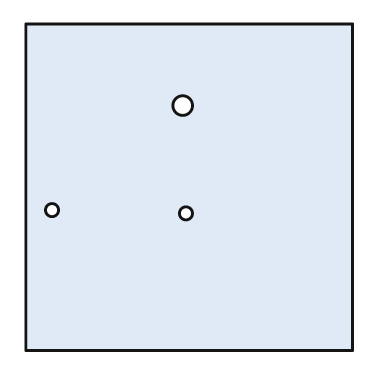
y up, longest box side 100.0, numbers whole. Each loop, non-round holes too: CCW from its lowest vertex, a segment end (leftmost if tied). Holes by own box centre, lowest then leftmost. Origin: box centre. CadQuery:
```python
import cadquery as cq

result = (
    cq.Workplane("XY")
    .moveTo(-50.0, -50.0)
    .lineTo(50.0, -50.0)
    .lineTo(50.0, 50.0)
    .lineTo(-50.0, 50.0)
    .close()
    .moveTo(-1.0, -8.0)
    .circle(2.0)
    .moveTo(-42.0, -7.0)
    .circle(2.0)
    .moveTo(-2.0, 25.0)
    .circle(3.0)
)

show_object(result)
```